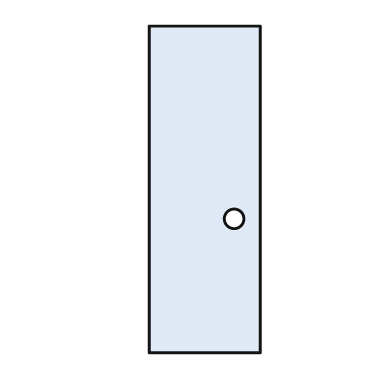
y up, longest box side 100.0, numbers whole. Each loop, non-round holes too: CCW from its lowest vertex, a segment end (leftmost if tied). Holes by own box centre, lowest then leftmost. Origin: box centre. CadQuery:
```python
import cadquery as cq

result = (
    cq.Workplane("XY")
    .moveTo(-17.0, -50.0)
    .lineTo(17.0, -50.0)
    .lineTo(17.0, 50.0)
    .lineTo(-17.0, 50.0)
    .close()
    .moveTo(9.0, -9.0)
    .circle(3.0)
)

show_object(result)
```